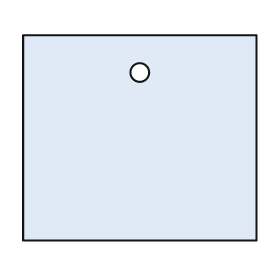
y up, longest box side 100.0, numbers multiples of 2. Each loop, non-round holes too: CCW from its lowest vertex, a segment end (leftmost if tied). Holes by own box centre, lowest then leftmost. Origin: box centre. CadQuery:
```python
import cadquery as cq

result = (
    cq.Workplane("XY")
    .moveTo(-50.0, -44.0)
    .lineTo(50.0, -44.0)
    .lineTo(50.0, 44.0)
    .lineTo(-50.0, 44.0)
    .close()
    .moveTo(0.0, 28.0)
    .circle(4.0)
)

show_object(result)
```